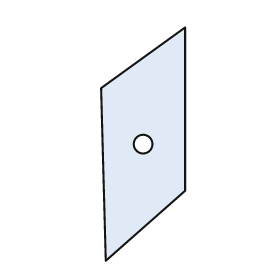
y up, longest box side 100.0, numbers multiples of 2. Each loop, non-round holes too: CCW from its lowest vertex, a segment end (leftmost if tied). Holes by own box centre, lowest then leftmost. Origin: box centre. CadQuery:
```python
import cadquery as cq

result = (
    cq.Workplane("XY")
    .moveTo(-16.0, -50.0)
    .lineTo(18.0, -20.0)
    .lineTo(18.0, 50.0)
    .lineTo(-18.0, 24.0)
    .close()
    .moveTo(0.0, 0.0)
    .circle(4.0)
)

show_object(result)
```